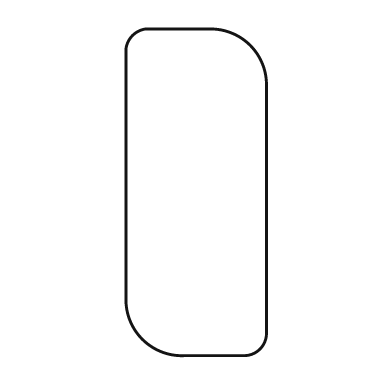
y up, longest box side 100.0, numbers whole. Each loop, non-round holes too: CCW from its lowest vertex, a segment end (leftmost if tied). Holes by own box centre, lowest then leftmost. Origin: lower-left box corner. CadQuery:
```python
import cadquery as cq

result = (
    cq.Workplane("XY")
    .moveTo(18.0, 0.0)
    .lineTo(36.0, 0.0)
    .threePointArc((41.0, 2.0), (43.0, 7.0))
    .lineTo(43.0, 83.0)
    .threePointArc((38.0, 95.0), (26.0, 100.0))
    .lineTo(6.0, 100.0)
    .threePointArc((2.0, 98.0), (0.0, 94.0))
    .lineTo(0.0, 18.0)
    .threePointArc((5.0, 5.0), (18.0, 0.0))
    .close()
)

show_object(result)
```